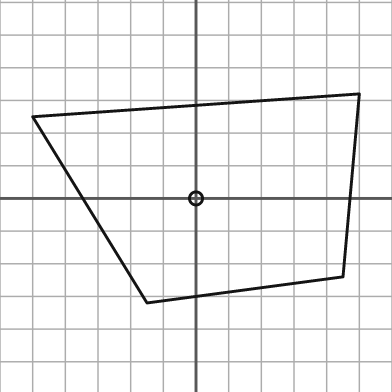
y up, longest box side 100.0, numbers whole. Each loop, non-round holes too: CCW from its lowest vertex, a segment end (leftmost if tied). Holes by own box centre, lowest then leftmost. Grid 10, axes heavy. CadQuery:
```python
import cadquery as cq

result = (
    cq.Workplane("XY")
    .moveTo(-15.0, -32.0)
    .lineTo(45.0, -24.0)
    .lineTo(50.0, 32.0)
    .lineTo(-50.0, 25.0)
    .close()
    .moveTo(0.0, 0.0)
    .circle(2.0)
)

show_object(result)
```